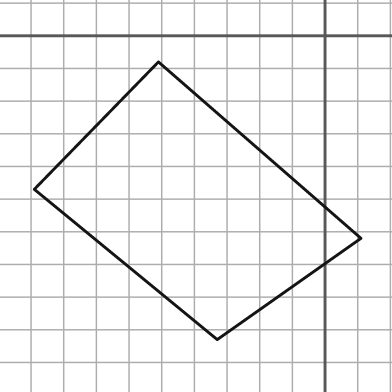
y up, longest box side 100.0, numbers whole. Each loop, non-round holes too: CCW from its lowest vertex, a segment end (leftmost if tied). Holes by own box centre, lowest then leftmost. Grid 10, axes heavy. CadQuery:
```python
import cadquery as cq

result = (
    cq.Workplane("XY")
    .moveTo(-33.0, -93.0)
    .lineTo(11.0, -62.0)
    .lineTo(-51.0, -8.0)
    .lineTo(-89.0, -47.0)
    .close()
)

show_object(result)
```